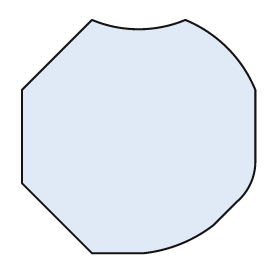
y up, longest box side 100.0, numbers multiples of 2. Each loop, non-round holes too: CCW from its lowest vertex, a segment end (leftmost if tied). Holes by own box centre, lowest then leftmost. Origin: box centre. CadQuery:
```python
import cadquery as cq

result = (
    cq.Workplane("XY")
    .moveTo(-20.0, -50.0)
    .lineTo(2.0, -50.0)
    .threePointArc((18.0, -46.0), (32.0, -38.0))
    .lineTo(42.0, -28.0)
    .threePointArc((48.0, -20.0), (50.0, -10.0))
    .lineTo(50.0, 20.0)
    .threePointArc((38.0, 38.0), (20.0, 50.0))
    .threePointArc((0.0, 46.0), (-20.0, 50.0))
    .lineTo(-50.0, 20.0)
    .lineTo(-50.0, -20.0)
    .close()
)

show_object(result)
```